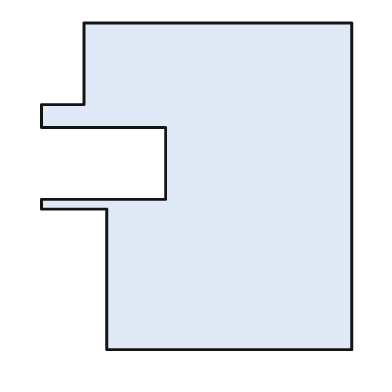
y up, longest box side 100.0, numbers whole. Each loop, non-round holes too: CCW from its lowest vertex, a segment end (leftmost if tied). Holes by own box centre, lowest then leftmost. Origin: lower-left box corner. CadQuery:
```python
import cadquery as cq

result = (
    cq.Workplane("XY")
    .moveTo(20.0, 0.0)
    .lineTo(95.0, 0.0)
    .lineTo(95.0, 100.0)
    .lineTo(13.0, 100.0)
    .lineTo(13.0, 75.0)
    .lineTo(0.0, 75.0)
    .lineTo(0.0, 68.0)
    .lineTo(38.0, 68.0)
    .lineTo(38.0, 46.0)
    .lineTo(0.0, 46.0)
    .lineTo(0.0, 43.0)
    .lineTo(20.0, 43.0)
    .close()
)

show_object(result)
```